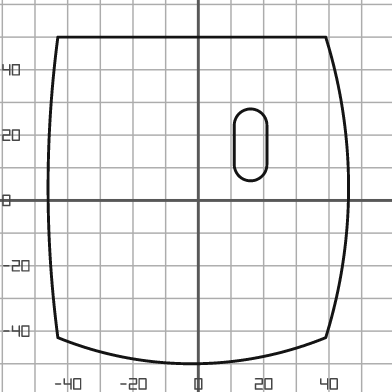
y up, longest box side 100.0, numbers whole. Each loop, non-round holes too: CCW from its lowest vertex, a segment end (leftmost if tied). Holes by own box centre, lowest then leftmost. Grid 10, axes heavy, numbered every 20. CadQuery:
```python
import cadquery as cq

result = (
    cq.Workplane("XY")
    .moveTo(-43.0, -42.0)
    .threePointArc((-2.0, -50.0), (39.0, -42.0))
    .threePointArc((46.0, 4.0), (39.0, 50.0))
    .lineTo(-43.0, 50.0)
    .threePointArc((-46.0, 4.0), (-43.0, -42.0))
    .close()
    .moveTo(11.0, 11.0)
    .threePointArc((16.0, 6.0), (21.0, 11.0))
    .lineTo(21.0, 23.0)
    .threePointArc((16.0, 28.0), (11.0, 23.0))
    .close()
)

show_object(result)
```